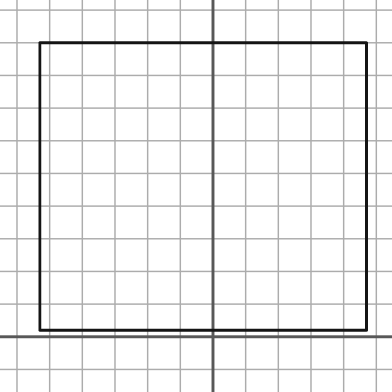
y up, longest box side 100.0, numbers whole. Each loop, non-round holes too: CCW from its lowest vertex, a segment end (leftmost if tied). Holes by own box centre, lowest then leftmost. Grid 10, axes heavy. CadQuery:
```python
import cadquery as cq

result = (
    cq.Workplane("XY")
    .moveTo(-53.0, 2.0)
    .lineTo(47.0, 2.0)
    .lineTo(47.0, 90.0)
    .lineTo(-53.0, 90.0)
    .close()
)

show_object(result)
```